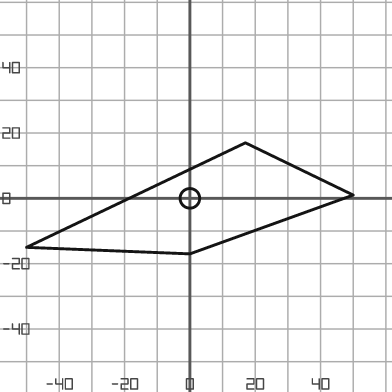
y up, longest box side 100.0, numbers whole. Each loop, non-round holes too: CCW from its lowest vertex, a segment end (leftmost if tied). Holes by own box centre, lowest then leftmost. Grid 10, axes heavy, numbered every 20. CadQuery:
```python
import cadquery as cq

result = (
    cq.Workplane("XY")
    .moveTo(0.0, -17.0)
    .lineTo(50.0, 1.0)
    .lineTo(17.0, 17.0)
    .lineTo(-50.0, -15.0)
    .close()
    .moveTo(0.0, 0.0)
    .circle(3.0)
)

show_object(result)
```